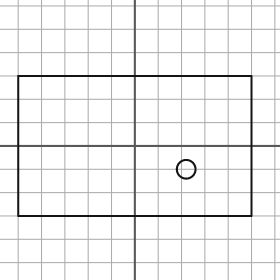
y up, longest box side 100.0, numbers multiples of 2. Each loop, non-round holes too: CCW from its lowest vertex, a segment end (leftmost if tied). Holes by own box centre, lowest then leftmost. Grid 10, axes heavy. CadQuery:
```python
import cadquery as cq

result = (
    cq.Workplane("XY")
    .moveTo(-50.0, -30.0)
    .lineTo(50.0, -30.0)
    .lineTo(50.0, 30.0)
    .lineTo(-50.0, 30.0)
    .close()
    .moveTo(22.0, -10.0)
    .circle(4.0)
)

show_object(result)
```